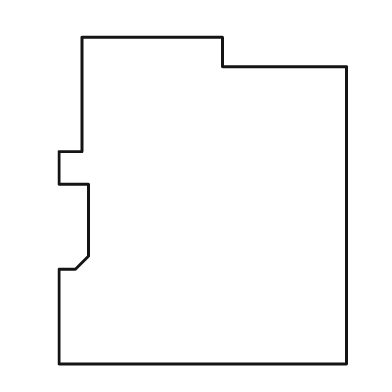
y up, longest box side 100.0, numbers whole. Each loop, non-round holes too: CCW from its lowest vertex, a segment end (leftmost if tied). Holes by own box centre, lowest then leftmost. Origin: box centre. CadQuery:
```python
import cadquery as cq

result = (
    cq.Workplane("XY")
    .moveTo(-44.0, -50.0)
    .lineTo(44.0, -50.0)
    .lineTo(44.0, 41.0)
    .lineTo(6.0, 41.0)
    .lineTo(6.0, 50.0)
    .lineTo(-37.0, 50.0)
    .lineTo(-37.0, 15.0)
    .lineTo(-44.0, 15.0)
    .lineTo(-44.0, 5.0)
    .lineTo(-35.0, 5.0)
    .lineTo(-35.0, -17.0)
    .lineTo(-39.0, -21.0)
    .lineTo(-44.0, -21.0)
    .close()
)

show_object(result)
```